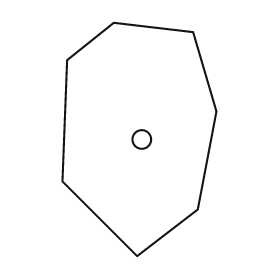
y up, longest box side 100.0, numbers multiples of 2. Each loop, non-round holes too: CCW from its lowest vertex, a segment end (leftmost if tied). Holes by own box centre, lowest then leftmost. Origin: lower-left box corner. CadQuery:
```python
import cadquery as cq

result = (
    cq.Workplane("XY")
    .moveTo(32.0, 0.0)
    .lineTo(58.0, 20.0)
    .lineTo(66.0, 62.0)
    .lineTo(56.0, 96.0)
    .lineTo(22.0, 100.0)
    .lineTo(2.0, 84.0)
    .lineTo(0.0, 32.0)
    .close()
    .moveTo(34.0, 50.0)
    .circle(4.0)
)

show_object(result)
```